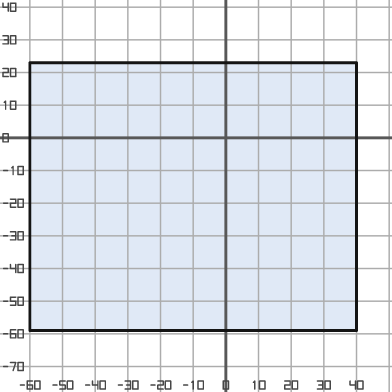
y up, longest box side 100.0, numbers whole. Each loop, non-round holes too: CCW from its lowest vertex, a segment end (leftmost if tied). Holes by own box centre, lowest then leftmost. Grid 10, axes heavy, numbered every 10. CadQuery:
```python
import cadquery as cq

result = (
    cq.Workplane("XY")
    .moveTo(-60.0, -59.0)
    .lineTo(40.0, -59.0)
    .lineTo(40.0, 23.0)
    .lineTo(-60.0, 23.0)
    .close()
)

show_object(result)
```